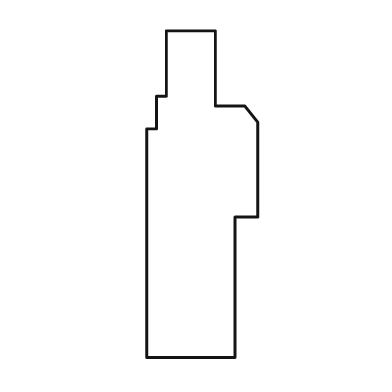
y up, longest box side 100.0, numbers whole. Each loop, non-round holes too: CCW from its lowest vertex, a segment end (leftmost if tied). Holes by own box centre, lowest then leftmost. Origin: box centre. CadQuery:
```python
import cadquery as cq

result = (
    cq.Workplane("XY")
    .moveTo(-17.0, -50.0)
    .lineTo(10.0, -50.0)
    .lineTo(10.0, -7.0)
    .lineTo(17.0, -7.0)
    .lineTo(17.0, 22.0)
    .lineTo(13.0, 27.0)
    .lineTo(4.0, 27.0)
    .lineTo(4.0, 50.0)
    .lineTo(-11.0, 50.0)
    .lineTo(-11.0, 30.0)
    .lineTo(-14.0, 30.0)
    .lineTo(-14.0, 20.0)
    .lineTo(-17.0, 20.0)
    .close()
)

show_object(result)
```